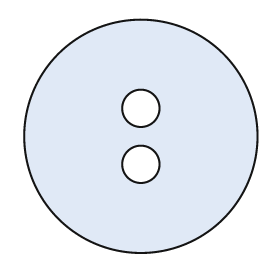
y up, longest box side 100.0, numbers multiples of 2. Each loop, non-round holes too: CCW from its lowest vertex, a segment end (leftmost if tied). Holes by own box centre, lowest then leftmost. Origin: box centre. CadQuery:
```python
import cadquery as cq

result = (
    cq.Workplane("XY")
    .moveTo(0.0, 0.0)
    .circle(50.0)
    .moveTo(0.0, -12.0)
    .circle(8.0)
    .moveTo(0.0, 12.0)
    .circle(8.0)
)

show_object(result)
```